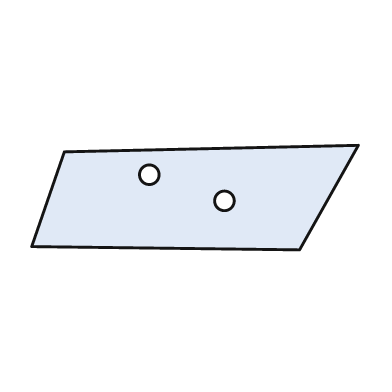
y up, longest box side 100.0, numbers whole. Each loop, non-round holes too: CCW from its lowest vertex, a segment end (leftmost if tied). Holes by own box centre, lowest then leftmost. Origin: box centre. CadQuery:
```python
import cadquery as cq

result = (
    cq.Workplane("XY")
    .moveTo(32.0, -16.0)
    .lineTo(50.0, 16.0)
    .lineTo(-40.0, 14.0)
    .lineTo(-50.0, -15.0)
    .close()
    .moveTo(9.0, -1.0)
    .circle(3.0)
    .moveTo(-14.0, 7.0)
    .circle(3.0)
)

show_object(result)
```